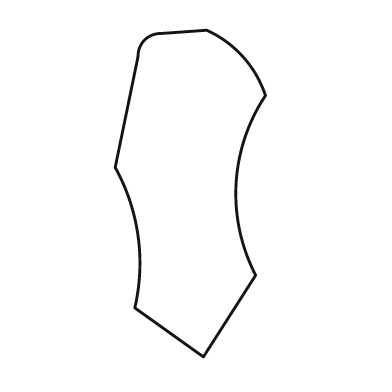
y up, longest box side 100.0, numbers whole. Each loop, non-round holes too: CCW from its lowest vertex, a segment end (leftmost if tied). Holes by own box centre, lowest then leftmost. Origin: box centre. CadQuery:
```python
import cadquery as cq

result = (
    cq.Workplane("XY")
    .moveTo(4.0, -50.0)
    .lineTo(20.0, -25.0)
    .threePointArc((14.0, 3.0), (23.0, 30.0))
    .threePointArc((16.0, 42.0), (5.0, 50.0))
    .lineTo(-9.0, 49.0)
    .threePointArc((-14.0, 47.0), (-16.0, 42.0))
    .lineTo(-23.0, 8.0)
    .threePointArc((-16.0, -13.0), (-17.0, -35.0))
    .close()
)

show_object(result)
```